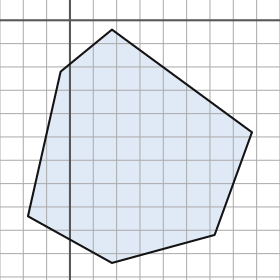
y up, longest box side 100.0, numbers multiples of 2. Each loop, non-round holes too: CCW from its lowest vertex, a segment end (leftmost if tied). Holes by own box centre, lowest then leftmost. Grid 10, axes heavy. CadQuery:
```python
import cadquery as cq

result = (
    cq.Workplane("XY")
    .moveTo(18.0, -104.0)
    .lineTo(62.0, -92.0)
    .lineTo(78.0, -48.0)
    .lineTo(18.0, -4.0)
    .lineTo(-4.0, -22.0)
    .lineTo(-18.0, -84.0)
    .close()
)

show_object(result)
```